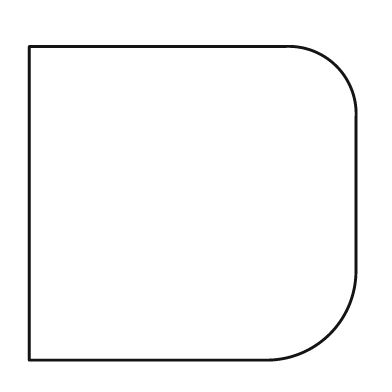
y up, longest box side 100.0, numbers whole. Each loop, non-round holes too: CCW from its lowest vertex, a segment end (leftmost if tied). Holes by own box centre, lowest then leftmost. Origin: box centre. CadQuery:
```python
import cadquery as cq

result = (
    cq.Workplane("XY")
    .moveTo(-50.0, -48.0)
    .lineTo(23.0, -48.0)
    .threePointArc((42.0, -40.0), (50.0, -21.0))
    .lineTo(50.0, 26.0)
    .threePointArc((44.0, 42.0), (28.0, 48.0))
    .lineTo(-50.0, 48.0)
    .close()
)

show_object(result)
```